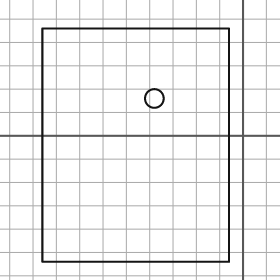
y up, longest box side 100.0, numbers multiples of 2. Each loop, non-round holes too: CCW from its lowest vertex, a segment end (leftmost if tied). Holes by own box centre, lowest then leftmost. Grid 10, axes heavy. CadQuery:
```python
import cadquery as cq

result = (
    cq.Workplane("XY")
    .moveTo(-86.0, -54.0)
    .lineTo(-6.0, -54.0)
    .lineTo(-6.0, 46.0)
    .lineTo(-86.0, 46.0)
    .close()
    .moveTo(-38.0, 16.0)
    .circle(4.0)
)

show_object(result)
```